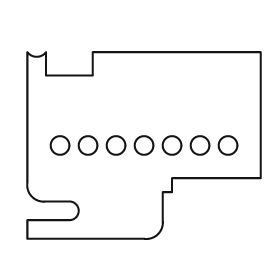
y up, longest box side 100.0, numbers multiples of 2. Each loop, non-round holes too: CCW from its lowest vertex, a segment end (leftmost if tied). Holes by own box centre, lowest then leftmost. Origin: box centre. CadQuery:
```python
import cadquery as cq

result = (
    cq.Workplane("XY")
    .moveTo(-50.0, -40.0)
    .lineTo(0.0, -40.0)
    .threePointArc((6.0, -38.0), (8.0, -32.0))
    .lineTo(8.0, -20.0)
    .lineTo(12.0, -20.0)
    .lineTo(12.0, -14.0)
    .lineTo(50.0, -14.0)
    .lineTo(50.0, 40.0)
    .lineTo(-22.0, 40.0)
    .lineTo(-22.0, 30.0)
    .lineTo(-42.0, 30.0)
    .lineTo(-42.0, 40.0)
    .threePointArc((-46.0, 38.0), (-50.0, 40.0))
    .lineTo(-50.0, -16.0)
    .threePointArc((-48.0, -22.0), (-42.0, -24.0))
    .lineTo(-32.0, -24.0)
    .threePointArc((-28.0, -28.0), (-32.0, -32.0))
    .lineTo(-50.0, -32.0)
    .close()
    .moveTo(-36.0, 0.0)
    .circle(4.0)
    .moveTo(-24.0, 0.0)
    .circle(4.0)
    .moveTo(-12.0, 0.0)
    .circle(4.0)
    .moveTo(0.0, 0.0)
    .circle(4.0)
    .moveTo(12.0, 0.0)
    .circle(4.0)
    .moveTo(24.0, 0.0)
    .circle(4.0)
    .moveTo(36.0, 0.0)
    .circle(4.0)
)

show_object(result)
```